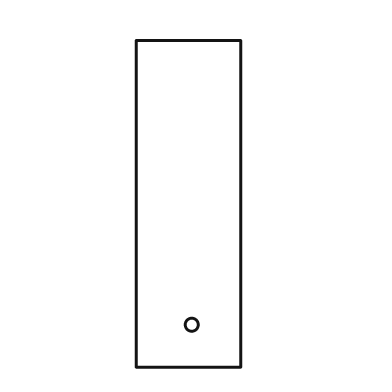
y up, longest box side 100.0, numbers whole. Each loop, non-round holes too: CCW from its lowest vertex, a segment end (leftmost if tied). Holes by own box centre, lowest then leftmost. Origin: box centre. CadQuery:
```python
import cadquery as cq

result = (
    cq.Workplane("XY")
    .moveTo(-16.0, -50.0)
    .lineTo(16.0, -50.0)
    .lineTo(16.0, 50.0)
    .lineTo(-16.0, 50.0)
    .close()
    .moveTo(1.0, -37.0)
    .circle(2.0)
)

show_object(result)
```